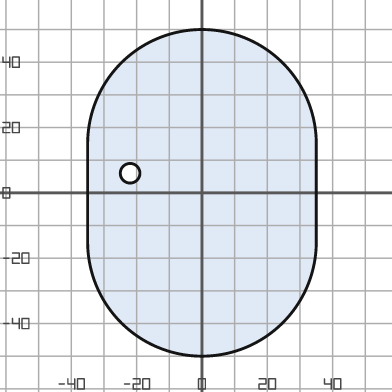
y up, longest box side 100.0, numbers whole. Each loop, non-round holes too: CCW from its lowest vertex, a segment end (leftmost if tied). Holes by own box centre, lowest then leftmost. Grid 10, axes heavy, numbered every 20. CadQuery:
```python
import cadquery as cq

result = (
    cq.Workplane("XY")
    .moveTo(-35.0, -15.0)
    .threePointArc((0.0, -50.0), (35.0, -15.0))
    .lineTo(35.0, 15.0)
    .threePointArc((0.0, 50.0), (-35.0, 15.0))
    .close()
    .moveTo(-22.0, 6.0)
    .circle(3.0)
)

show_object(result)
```